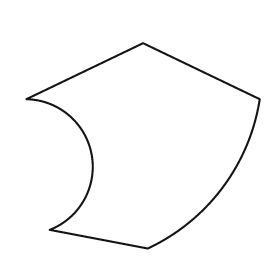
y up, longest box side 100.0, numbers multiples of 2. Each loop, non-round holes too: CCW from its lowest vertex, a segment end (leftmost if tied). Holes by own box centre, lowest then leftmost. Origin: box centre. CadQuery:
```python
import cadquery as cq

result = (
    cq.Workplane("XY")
    .moveTo(2.0, -44.0)
    .threePointArc((34.0, -18.0), (50.0, 20.0))
    .lineTo(0.0, 44.0)
    .lineTo(-50.0, 20.0)
    .threePointArc((-22.0, -4.0), (-40.0, -36.0))
    .close()
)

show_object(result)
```